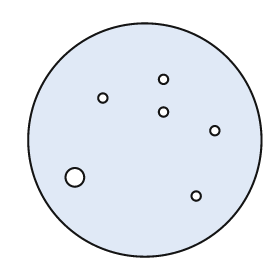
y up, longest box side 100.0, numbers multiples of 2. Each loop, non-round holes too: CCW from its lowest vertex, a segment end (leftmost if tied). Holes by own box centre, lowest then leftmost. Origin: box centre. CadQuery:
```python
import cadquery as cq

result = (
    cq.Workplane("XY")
    .moveTo(0.0, 0.0)
    .circle(50.0)
    .moveTo(22.0, -24.0)
    .circle(2.0)
    .moveTo(-30.0, -16.0)
    .circle(4.0)
    .moveTo(30.0, 4.0)
    .circle(2.0)
    .moveTo(8.0, 12.0)
    .circle(2.0)
    .moveTo(-18.0, 18.0)
    .circle(2.0)
    .moveTo(8.0, 26.0)
    .circle(2.0)
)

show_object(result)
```